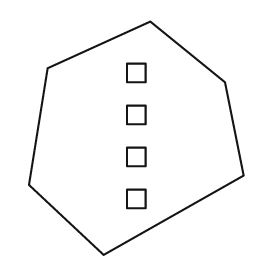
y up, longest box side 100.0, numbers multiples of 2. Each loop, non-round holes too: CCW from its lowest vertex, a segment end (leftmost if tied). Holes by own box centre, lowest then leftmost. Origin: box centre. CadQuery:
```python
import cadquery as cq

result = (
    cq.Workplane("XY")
    .moveTo(-14.0, -50.0)
    .lineTo(46.0, -16.0)
    .lineTo(38.0, 24.0)
    .lineTo(6.0, 50.0)
    .lineTo(-38.0, 30.0)
    .lineTo(-46.0, -20.0)
    .close()
    .moveTo(-4.0, -30.0)
    .lineTo(4.0, -30.0)
    .lineTo(4.0, -22.0)
    .lineTo(-4.0, -22.0)
    .close()
    .moveTo(-4.0, -12.0)
    .lineTo(4.0, -12.0)
    .lineTo(4.0, -4.0)
    .lineTo(-4.0, -4.0)
    .close()
    .moveTo(-4.0, 6.0)
    .lineTo(4.0, 6.0)
    .lineTo(4.0, 14.0)
    .lineTo(-4.0, 14.0)
    .close()
    .moveTo(-4.0, 24.0)
    .lineTo(4.0, 24.0)
    .lineTo(4.0, 32.0)
    .lineTo(-4.0, 32.0)
    .close()
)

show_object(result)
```